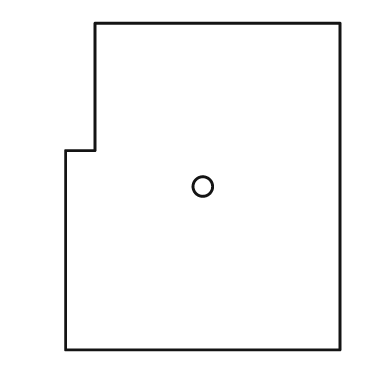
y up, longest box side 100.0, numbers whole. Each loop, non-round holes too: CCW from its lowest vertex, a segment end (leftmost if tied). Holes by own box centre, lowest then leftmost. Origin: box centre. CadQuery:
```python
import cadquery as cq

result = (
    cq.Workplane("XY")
    .moveTo(-42.0, -50.0)
    .lineTo(42.0, -50.0)
    .lineTo(42.0, 50.0)
    .lineTo(-33.0, 50.0)
    .lineTo(-33.0, 11.0)
    .lineTo(-42.0, 11.0)
    .close()
    .moveTo(0.0, 0.0)
    .circle(3.0)
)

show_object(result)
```